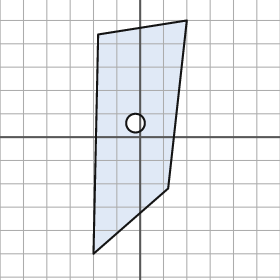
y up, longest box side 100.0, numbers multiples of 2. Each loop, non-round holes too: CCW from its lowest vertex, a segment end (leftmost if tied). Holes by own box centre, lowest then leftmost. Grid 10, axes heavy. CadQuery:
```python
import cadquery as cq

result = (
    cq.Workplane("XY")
    .moveTo(-20.0, -50.0)
    .lineTo(12.0, -22.0)
    .lineTo(20.0, 50.0)
    .lineTo(-18.0, 44.0)
    .close()
    .moveTo(-2.0, 6.0)
    .circle(4.0)
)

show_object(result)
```